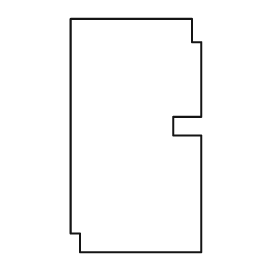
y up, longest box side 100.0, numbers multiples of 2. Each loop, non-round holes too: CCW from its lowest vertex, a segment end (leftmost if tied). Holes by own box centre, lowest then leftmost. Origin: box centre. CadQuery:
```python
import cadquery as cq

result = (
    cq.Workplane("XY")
    .moveTo(-24.0, -50.0)
    .lineTo(28.0, -50.0)
    .lineTo(28.0, 0.0)
    .lineTo(16.0, 0.0)
    .lineTo(16.0, 8.0)
    .lineTo(28.0, 8.0)
    .lineTo(28.0, 40.0)
    .lineTo(24.0, 40.0)
    .lineTo(24.0, 50.0)
    .lineTo(-28.0, 50.0)
    .lineTo(-28.0, -42.0)
    .lineTo(-24.0, -42.0)
    .close()
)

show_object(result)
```